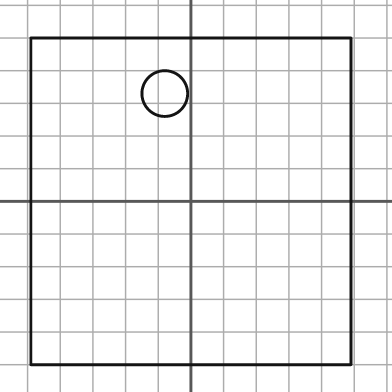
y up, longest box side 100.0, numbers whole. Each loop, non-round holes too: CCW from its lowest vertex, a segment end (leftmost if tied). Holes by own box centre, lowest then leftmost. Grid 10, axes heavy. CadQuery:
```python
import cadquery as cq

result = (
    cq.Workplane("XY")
    .moveTo(-49.0, -50.0)
    .lineTo(49.0, -50.0)
    .lineTo(49.0, 50.0)
    .lineTo(-49.0, 50.0)
    .close()
    .moveTo(-8.0, 33.0)
    .circle(7.0)
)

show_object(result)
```